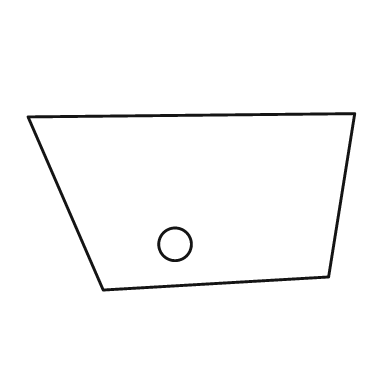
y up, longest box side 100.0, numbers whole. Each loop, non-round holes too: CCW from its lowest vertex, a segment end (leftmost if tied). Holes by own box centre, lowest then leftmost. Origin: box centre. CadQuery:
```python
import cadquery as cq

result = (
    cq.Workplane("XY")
    .moveTo(-27.0, -27.0)
    .lineTo(42.0, -23.0)
    .lineTo(50.0, 27.0)
    .lineTo(-50.0, 26.0)
    .close()
    .moveTo(-5.0, -13.0)
    .circle(5.0)
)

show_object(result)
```